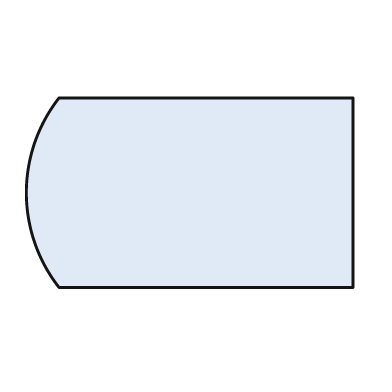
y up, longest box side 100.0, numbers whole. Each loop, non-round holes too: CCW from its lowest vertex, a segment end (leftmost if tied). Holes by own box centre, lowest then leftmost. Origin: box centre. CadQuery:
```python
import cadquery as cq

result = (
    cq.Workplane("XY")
    .moveTo(-40.0, -29.0)
    .lineTo(50.0, -29.0)
    .lineTo(50.0, 29.0)
    .lineTo(-40.0, 29.0)
    .threePointArc((-50.0, 0.0), (-40.0, -29.0))
    .close()
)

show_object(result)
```